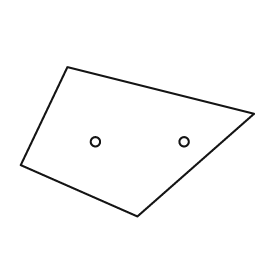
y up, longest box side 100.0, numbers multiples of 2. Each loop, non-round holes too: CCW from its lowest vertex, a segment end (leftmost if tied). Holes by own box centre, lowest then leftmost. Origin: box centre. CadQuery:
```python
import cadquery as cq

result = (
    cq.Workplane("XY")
    .moveTo(0.0, -32.0)
    .lineTo(50.0, 12.0)
    .lineTo(-30.0, 32.0)
    .lineTo(-50.0, -10.0)
    .close()
    .moveTo(-18.0, 0.0)
    .circle(2.0)
    .moveTo(20.0, 0.0)
    .circle(2.0)
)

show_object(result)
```